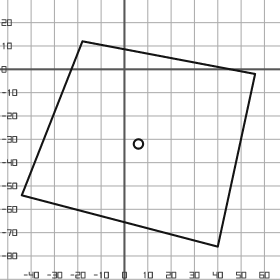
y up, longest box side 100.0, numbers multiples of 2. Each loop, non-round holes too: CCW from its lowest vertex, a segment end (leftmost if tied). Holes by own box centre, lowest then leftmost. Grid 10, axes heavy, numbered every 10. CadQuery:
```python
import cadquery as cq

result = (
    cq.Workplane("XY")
    .moveTo(40.0, -76.0)
    .lineTo(56.0, -2.0)
    .lineTo(-18.0, 12.0)
    .lineTo(-44.0, -54.0)
    .close()
    .moveTo(6.0, -32.0)
    .circle(2.0)
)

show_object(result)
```